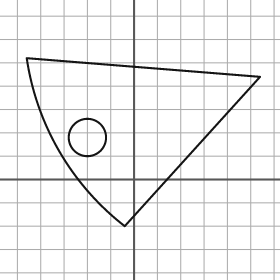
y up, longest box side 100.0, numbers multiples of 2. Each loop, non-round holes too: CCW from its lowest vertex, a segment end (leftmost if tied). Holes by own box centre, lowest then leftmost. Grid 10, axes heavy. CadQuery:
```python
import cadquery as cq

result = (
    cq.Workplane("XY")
    .moveTo(-4.0, -20.0)
    .lineTo(54.0, 44.0)
    .lineTo(-46.0, 52.0)
    .threePointArc((-32.0, 12.0), (-4.0, -20.0))
    .close()
    .moveTo(-20.0, 18.0)
    .circle(8.0)
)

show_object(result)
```